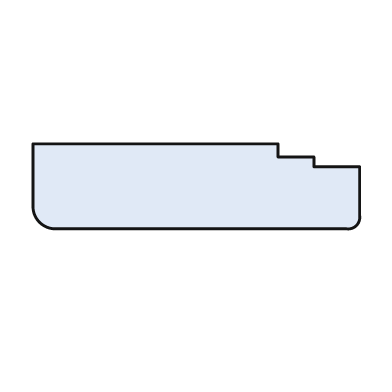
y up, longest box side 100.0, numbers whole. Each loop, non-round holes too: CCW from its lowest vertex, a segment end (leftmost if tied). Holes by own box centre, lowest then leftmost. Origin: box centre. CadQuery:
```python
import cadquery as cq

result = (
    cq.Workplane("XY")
    .moveTo(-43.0, -13.0)
    .lineTo(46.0, -13.0)
    .threePointArc((49.0, -12.0), (50.0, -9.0))
    .lineTo(50.0, 6.0)
    .lineTo(36.0, 6.0)
    .lineTo(36.0, 9.0)
    .lineTo(25.0, 9.0)
    .lineTo(25.0, 13.0)
    .lineTo(-50.0, 13.0)
    .lineTo(-50.0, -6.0)
    .threePointArc((-48.0, -11.0), (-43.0, -13.0))
    .close()
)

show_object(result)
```